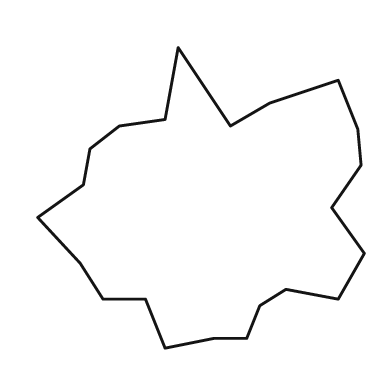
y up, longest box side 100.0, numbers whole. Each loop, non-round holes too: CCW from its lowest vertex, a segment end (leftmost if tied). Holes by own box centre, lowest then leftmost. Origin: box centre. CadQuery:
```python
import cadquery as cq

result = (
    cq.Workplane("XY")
    .moveTo(-11.0, -46.0)
    .lineTo(4.0, -43.0)
    .lineTo(14.0, -43.0)
    .lineTo(18.0, -33.0)
    .lineTo(26.0, -28.0)
    .lineTo(42.0, -31.0)
    .lineTo(50.0, -17.0)
    .lineTo(40.0, -3.0)
    .lineTo(49.0, 10.0)
    .lineTo(48.0, 21.0)
    .lineTo(42.0, 36.0)
    .lineTo(21.0, 29.0)
    .lineTo(9.0, 22.0)
    .lineTo(-7.0, 46.0)
    .lineTo(-11.0, 24.0)
    .lineTo(-25.0, 22.0)
    .lineTo(-34.0, 15.0)
    .lineTo(-36.0, 4.0)
    .lineTo(-50.0, -6.0)
    .lineTo(-37.0, -20.0)
    .lineTo(-30.0, -31.0)
    .lineTo(-17.0, -31.0)
    .close()
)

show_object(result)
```